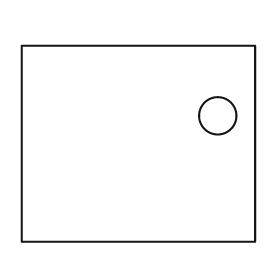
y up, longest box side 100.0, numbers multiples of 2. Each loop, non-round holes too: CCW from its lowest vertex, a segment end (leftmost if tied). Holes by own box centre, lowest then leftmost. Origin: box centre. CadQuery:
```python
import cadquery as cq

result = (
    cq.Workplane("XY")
    .moveTo(-50.0, -42.0)
    .lineTo(50.0, -42.0)
    .lineTo(50.0, 42.0)
    .lineTo(-50.0, 42.0)
    .close()
    .moveTo(34.0, 12.0)
    .circle(8.0)
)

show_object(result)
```